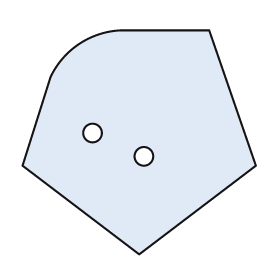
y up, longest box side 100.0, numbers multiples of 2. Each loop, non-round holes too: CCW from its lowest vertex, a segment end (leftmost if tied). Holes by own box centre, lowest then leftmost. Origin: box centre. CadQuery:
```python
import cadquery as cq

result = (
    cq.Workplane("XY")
    .moveTo(0.0, -48.0)
    .lineTo(50.0, -10.0)
    .lineTo(30.0, 48.0)
    .lineTo(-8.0, 48.0)
    .threePointArc((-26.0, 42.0), (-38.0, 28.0))
    .lineTo(-50.0, -10.0)
    .close()
    .moveTo(2.0, -6.0)
    .circle(4.0)
    .moveTo(-20.0, 4.0)
    .circle(4.0)
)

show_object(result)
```